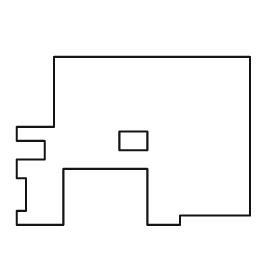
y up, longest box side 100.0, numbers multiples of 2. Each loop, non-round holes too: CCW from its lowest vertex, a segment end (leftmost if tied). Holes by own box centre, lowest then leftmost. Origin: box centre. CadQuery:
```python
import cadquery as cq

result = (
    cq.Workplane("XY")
    .moveTo(-50.0, -36.0)
    .lineTo(-30.0, -36.0)
    .lineTo(-30.0, -12.0)
    .lineTo(6.0, -12.0)
    .lineTo(6.0, -36.0)
    .lineTo(20.0, -36.0)
    .lineTo(20.0, -32.0)
    .lineTo(50.0, -32.0)
    .lineTo(50.0, 36.0)
    .lineTo(-34.0, 36.0)
    .lineTo(-34.0, 6.0)
    .lineTo(-50.0, 6.0)
    .lineTo(-50.0, 0.0)
    .lineTo(-38.0, 0.0)
    .lineTo(-38.0, -8.0)
    .lineTo(-50.0, -8.0)
    .lineTo(-50.0, -16.0)
    .lineTo(-46.0, -16.0)
    .lineTo(-46.0, -30.0)
    .lineTo(-50.0, -30.0)
    .close()
    .moveTo(-6.0, -4.0)
    .lineTo(6.0, -4.0)
    .lineTo(6.0, 4.0)
    .lineTo(-6.0, 4.0)
    .close()
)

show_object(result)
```